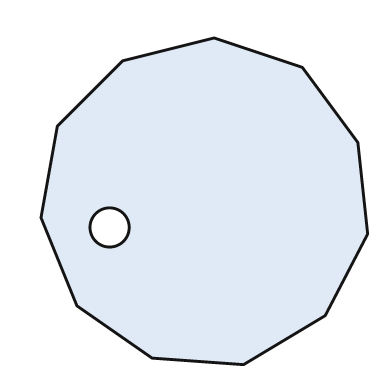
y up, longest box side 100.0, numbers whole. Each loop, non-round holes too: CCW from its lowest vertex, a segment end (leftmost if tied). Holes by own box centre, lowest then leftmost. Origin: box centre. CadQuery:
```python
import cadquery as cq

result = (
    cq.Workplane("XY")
    .moveTo(12.0, -50.0)
    .lineTo(37.0, -35.0)
    .lineTo(50.0, -10.0)
    .lineTo(47.0, 18.0)
    .lineTo(30.0, 41.0)
    .lineTo(3.0, 50.0)
    .lineTo(-25.0, 43.0)
    .lineTo(-45.0, 23.0)
    .lineTo(-50.0, -5.0)
    .lineTo(-39.0, -32.0)
    .lineTo(-16.0, -48.0)
    .close()
    .moveTo(-29.0, -8.0)
    .circle(6.0)
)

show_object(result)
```